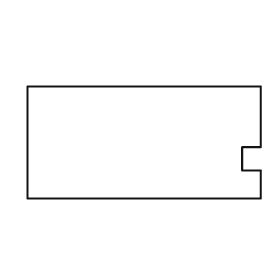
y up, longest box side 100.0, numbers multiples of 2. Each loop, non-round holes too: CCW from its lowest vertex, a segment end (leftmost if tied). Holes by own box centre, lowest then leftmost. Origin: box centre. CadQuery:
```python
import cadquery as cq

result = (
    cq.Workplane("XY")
    .moveTo(-50.0, -24.0)
    .lineTo(50.0, -24.0)
    .lineTo(50.0, -12.0)
    .lineTo(42.0, -12.0)
    .lineTo(42.0, -2.0)
    .lineTo(50.0, -2.0)
    .lineTo(50.0, 24.0)
    .lineTo(-50.0, 24.0)
    .close()
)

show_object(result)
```